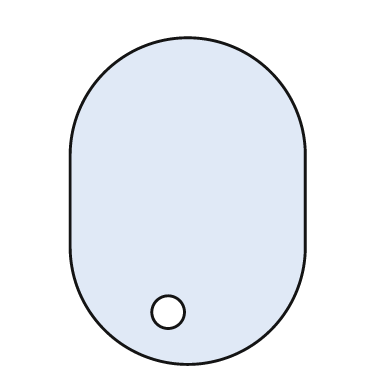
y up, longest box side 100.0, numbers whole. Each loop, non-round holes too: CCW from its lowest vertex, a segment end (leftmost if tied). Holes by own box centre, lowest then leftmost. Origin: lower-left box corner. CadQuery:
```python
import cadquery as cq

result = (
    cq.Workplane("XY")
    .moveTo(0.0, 36.0)
    .threePointArc((36.0, 0.0), (72.0, 36.0))
    .lineTo(72.0, 64.0)
    .threePointArc((36.0, 100.0), (0.0, 64.0))
    .close()
    .moveTo(30.0, 16.0)
    .circle(5.0)
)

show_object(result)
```